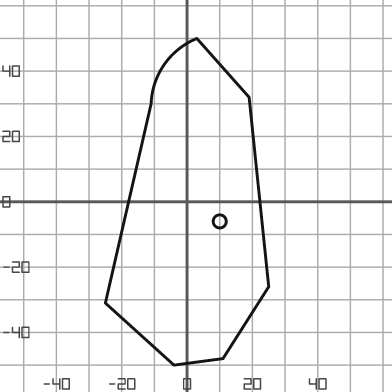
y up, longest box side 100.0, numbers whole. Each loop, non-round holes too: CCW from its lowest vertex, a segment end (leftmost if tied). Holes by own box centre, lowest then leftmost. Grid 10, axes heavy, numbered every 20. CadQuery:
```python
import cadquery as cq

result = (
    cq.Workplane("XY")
    .moveTo(-4.0, -50.0)
    .lineTo(11.0, -48.0)
    .lineTo(25.0, -26.0)
    .lineTo(19.0, 32.0)
    .lineTo(3.0, 50.0)
    .threePointArc((-7.0, 42.0), (-11.0, 30.0))
    .lineTo(-25.0, -31.0)
    .close()
    .moveTo(10.0, -6.0)
    .circle(2.0)
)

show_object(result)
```